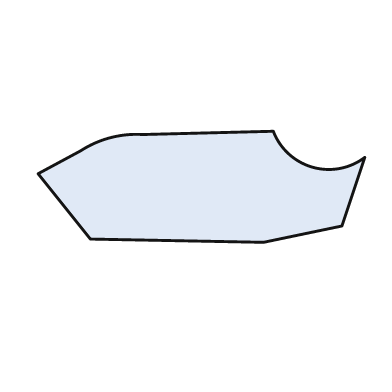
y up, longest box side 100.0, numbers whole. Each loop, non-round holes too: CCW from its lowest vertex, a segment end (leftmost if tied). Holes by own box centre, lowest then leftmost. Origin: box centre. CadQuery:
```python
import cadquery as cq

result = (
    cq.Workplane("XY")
    .moveTo(19.0, -17.0)
    .lineTo(43.0, -12.0)
    .lineTo(50.0, 9.0)
    .threePointArc((34.0, 6.0), (22.0, 17.0))
    .lineTo(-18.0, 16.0)
    .threePointArc((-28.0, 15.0), (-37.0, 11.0))
    .lineTo(-50.0, 4.0)
    .lineTo(-34.0, -16.0)
    .close()
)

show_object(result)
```